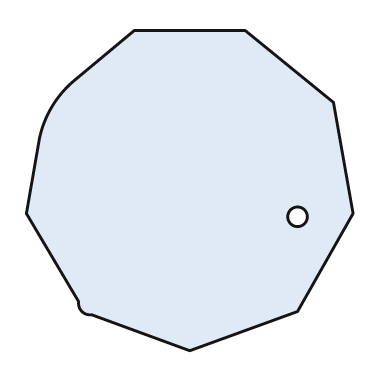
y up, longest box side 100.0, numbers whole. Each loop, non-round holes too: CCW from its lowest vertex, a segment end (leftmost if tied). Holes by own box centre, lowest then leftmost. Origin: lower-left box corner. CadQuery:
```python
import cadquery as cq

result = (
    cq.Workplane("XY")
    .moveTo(50.0, 0.0)
    .lineTo(83.0, 12.0)
    .lineTo(100.0, 42.0)
    .lineTo(94.0, 76.0)
    .lineTo(67.0, 98.0)
    .lineTo(33.0, 98.0)
    .lineTo(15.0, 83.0)
    .threePointArc((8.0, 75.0), (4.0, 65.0))
    .lineTo(0.0, 42.0)
    .lineTo(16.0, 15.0)
    .threePointArc((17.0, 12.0), (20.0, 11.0))
    .close()
    .moveTo(83.0, 41.0)
    .circle(3.0)
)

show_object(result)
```